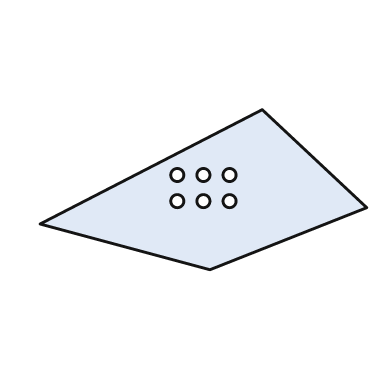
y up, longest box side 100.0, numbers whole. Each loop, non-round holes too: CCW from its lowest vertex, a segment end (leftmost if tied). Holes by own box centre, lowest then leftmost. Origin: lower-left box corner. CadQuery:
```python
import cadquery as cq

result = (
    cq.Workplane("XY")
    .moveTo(52.0, 0.0)
    .lineTo(100.0, 19.0)
    .lineTo(68.0, 49.0)
    .lineTo(0.0, 14.0)
    .close()
    .moveTo(42.0, 21.0)
    .circle(2.0)
    .moveTo(50.0, 21.0)
    .circle(2.0)
    .moveTo(58.0, 21.0)
    .circle(2.0)
    .moveTo(42.0, 29.0)
    .circle(2.0)
    .moveTo(50.0, 29.0)
    .circle(2.0)
    .moveTo(58.0, 29.0)
    .circle(2.0)
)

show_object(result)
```